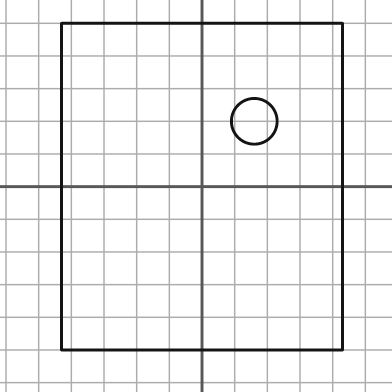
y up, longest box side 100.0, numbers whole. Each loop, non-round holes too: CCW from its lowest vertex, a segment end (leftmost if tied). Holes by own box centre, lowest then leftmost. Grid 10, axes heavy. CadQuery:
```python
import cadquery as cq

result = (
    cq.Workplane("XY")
    .moveTo(-43.0, -50.0)
    .lineTo(43.0, -50.0)
    .lineTo(43.0, 50.0)
    .lineTo(-43.0, 50.0)
    .close()
    .moveTo(16.0, 20.0)
    .circle(7.0)
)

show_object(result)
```